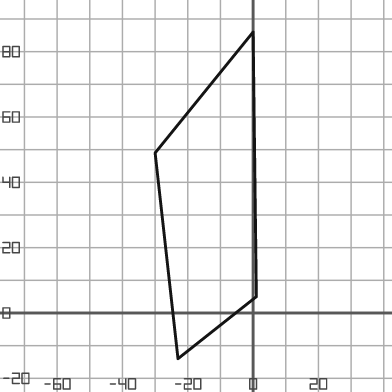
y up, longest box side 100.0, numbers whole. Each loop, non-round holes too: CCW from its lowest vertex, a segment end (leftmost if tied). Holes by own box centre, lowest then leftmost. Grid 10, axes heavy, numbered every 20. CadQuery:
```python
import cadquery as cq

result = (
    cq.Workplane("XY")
    .moveTo(-23.0, -14.0)
    .lineTo(1.0, 5.0)
    .lineTo(0.0, 86.0)
    .lineTo(-30.0, 49.0)
    .close()
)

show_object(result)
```